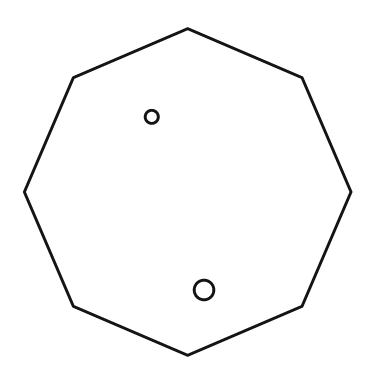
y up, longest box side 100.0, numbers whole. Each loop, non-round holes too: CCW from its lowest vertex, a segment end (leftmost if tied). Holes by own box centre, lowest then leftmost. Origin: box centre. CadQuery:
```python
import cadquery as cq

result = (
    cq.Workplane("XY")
    .moveTo(0.0, -50.0)
    .lineTo(35.0, -35.0)
    .lineTo(50.0, 0.0)
    .lineTo(35.0, 35.0)
    .lineTo(0.0, 50.0)
    .lineTo(-35.0, 35.0)
    .lineTo(-50.0, 0.0)
    .lineTo(-35.0, -35.0)
    .close()
    .moveTo(5.0, -30.0)
    .circle(3.0)
    .moveTo(-11.0, 23.0)
    .circle(2.0)
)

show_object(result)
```